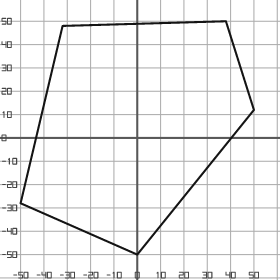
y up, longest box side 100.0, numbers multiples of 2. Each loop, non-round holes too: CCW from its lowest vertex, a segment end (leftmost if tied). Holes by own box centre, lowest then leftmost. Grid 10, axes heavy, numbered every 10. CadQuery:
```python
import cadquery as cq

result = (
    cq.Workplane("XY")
    .moveTo(0.0, -50.0)
    .lineTo(50.0, 12.0)
    .lineTo(38.0, 50.0)
    .lineTo(-32.0, 48.0)
    .lineTo(-50.0, -28.0)
    .close()
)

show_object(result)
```